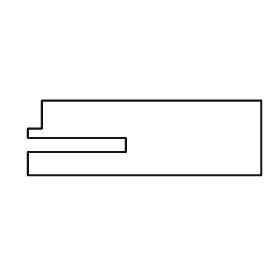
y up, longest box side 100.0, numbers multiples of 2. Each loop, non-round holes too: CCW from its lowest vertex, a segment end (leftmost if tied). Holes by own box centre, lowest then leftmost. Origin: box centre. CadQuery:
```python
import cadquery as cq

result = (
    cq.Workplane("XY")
    .moveTo(-50.0, -16.0)
    .lineTo(50.0, -16.0)
    .lineTo(50.0, 16.0)
    .lineTo(-44.0, 16.0)
    .lineTo(-44.0, 4.0)
    .lineTo(-50.0, 4.0)
    .lineTo(-50.0, 0.0)
    .lineTo(-8.0, 0.0)
    .lineTo(-8.0, -6.0)
    .lineTo(-50.0, -6.0)
    .close()
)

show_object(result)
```